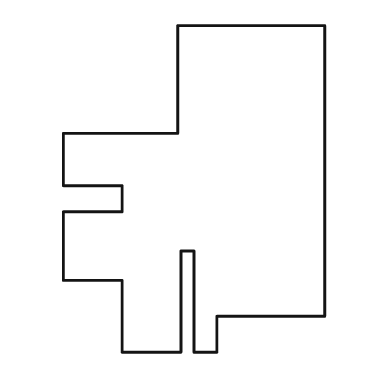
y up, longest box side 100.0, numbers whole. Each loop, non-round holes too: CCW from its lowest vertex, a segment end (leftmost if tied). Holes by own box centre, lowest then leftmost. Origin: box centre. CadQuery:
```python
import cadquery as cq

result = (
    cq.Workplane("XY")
    .moveTo(-22.0, -50.0)
    .lineTo(-4.0, -50.0)
    .lineTo(-4.0, -19.0)
    .lineTo(0.0, -19.0)
    .lineTo(0.0, -50.0)
    .lineTo(7.0, -50.0)
    .lineTo(7.0, -39.0)
    .lineTo(40.0, -39.0)
    .lineTo(40.0, 50.0)
    .lineTo(-5.0, 50.0)
    .lineTo(-5.0, 17.0)
    .lineTo(-40.0, 17.0)
    .lineTo(-40.0, 1.0)
    .lineTo(-22.0, 1.0)
    .lineTo(-22.0, -7.0)
    .lineTo(-40.0, -7.0)
    .lineTo(-40.0, -28.0)
    .lineTo(-22.0, -28.0)
    .close()
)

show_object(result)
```